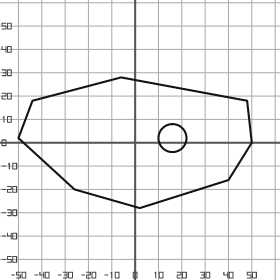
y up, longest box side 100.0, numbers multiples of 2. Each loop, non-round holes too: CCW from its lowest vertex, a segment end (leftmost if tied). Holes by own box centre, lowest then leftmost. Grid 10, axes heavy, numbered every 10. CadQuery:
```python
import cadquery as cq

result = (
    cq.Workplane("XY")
    .moveTo(2.0, -28.0)
    .lineTo(40.0, -16.0)
    .lineTo(50.0, 0.0)
    .lineTo(48.0, 18.0)
    .lineTo(-6.0, 28.0)
    .lineTo(-44.0, 18.0)
    .lineTo(-50.0, 2.0)
    .lineTo(-26.0, -20.0)
    .close()
    .moveTo(16.0, 2.0)
    .circle(6.0)
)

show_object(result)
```